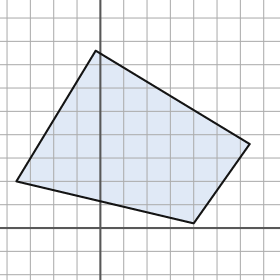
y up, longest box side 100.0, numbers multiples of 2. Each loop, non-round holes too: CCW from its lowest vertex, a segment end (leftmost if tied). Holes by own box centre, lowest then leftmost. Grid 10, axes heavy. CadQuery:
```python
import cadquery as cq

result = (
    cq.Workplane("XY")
    .moveTo(40.0, 2.0)
    .lineTo(64.0, 36.0)
    .lineTo(-2.0, 76.0)
    .lineTo(-36.0, 20.0)
    .close()
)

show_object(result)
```